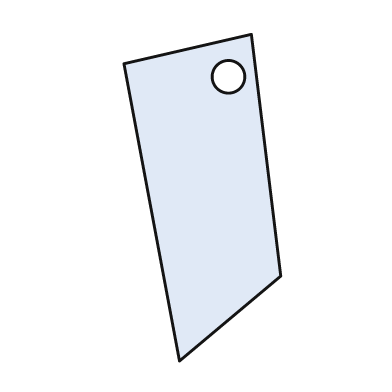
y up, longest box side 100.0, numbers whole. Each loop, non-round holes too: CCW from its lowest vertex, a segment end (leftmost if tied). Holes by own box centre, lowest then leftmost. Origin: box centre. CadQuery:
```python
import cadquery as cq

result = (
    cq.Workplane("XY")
    .moveTo(-7.0, -50.0)
    .lineTo(24.0, -24.0)
    .lineTo(15.0, 50.0)
    .lineTo(-24.0, 41.0)
    .close()
    .moveTo(8.0, 37.0)
    .circle(5.0)
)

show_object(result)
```